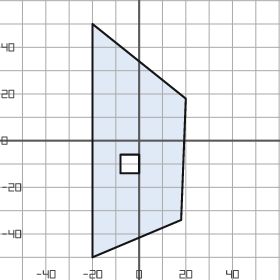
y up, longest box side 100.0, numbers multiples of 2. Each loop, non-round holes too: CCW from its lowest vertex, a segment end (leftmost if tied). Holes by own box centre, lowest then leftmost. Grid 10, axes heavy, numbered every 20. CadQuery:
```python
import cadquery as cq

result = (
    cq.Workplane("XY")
    .moveTo(-20.0, -50.0)
    .lineTo(18.0, -34.0)
    .lineTo(20.0, 18.0)
    .lineTo(-20.0, 50.0)
    .close()
    .moveTo(-8.0, -14.0)
    .lineTo(0.0, -14.0)
    .lineTo(0.0, -6.0)
    .lineTo(-8.0, -6.0)
    .close()
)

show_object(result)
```